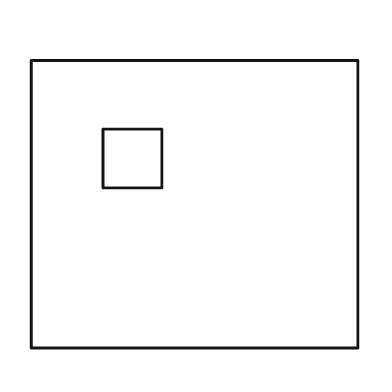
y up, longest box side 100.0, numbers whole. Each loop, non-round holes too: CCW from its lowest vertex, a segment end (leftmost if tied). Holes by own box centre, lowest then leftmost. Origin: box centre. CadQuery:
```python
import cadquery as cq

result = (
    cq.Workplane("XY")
    .moveTo(-50.0, -44.0)
    .lineTo(50.0, -44.0)
    .lineTo(50.0, 44.0)
    .lineTo(-50.0, 44.0)
    .close()
    .moveTo(-28.0, 5.0)
    .lineTo(-10.0, 5.0)
    .lineTo(-10.0, 23.0)
    .lineTo(-28.0, 23.0)
    .close()
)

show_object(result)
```